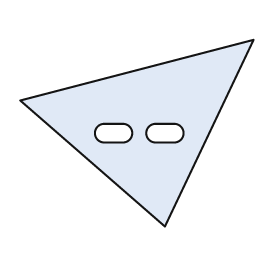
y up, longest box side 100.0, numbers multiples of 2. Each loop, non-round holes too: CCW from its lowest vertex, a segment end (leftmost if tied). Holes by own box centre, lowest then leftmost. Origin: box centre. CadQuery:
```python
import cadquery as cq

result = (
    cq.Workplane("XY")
    .moveTo(12.0, -40.0)
    .lineTo(50.0, 40.0)
    .lineTo(-50.0, 14.0)
    .close()
    .moveTo(-14.0, -4.0)
    .lineTo(-6.0, -4.0)
    .threePointArc((-2.0, 0.0), (-6.0, 4.0))
    .lineTo(-14.0, 4.0)
    .threePointArc((-18.0, 0.0), (-14.0, -4.0))
    .close()
    .moveTo(8.0, -4.0)
    .lineTo(16.0, -4.0)
    .threePointArc((20.0, 0.0), (16.0, 4.0))
    .lineTo(8.0, 4.0)
    .threePointArc((4.0, 0.0), (8.0, -4.0))
    .close()
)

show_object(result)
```